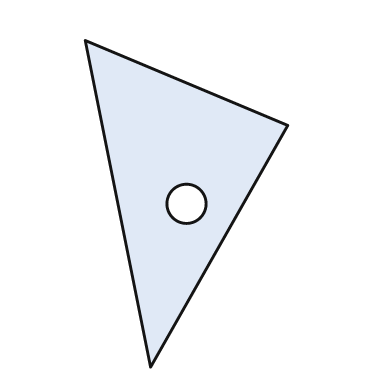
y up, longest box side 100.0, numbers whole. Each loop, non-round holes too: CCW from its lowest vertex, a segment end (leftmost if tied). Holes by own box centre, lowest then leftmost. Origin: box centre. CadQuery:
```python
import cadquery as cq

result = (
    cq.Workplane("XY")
    .moveTo(-11.0, -50.0)
    .lineTo(31.0, 24.0)
    .lineTo(-31.0, 50.0)
    .close()
    .moveTo(0.0, 0.0)
    .circle(6.0)
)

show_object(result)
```